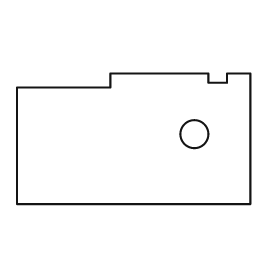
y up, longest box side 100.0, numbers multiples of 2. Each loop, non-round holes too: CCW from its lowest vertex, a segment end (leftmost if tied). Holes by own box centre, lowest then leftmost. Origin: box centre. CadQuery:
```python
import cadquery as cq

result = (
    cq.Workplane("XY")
    .moveTo(-50.0, -28.0)
    .lineTo(50.0, -28.0)
    .lineTo(50.0, 28.0)
    .lineTo(40.0, 28.0)
    .lineTo(40.0, 24.0)
    .lineTo(32.0, 24.0)
    .lineTo(32.0, 28.0)
    .lineTo(-10.0, 28.0)
    .lineTo(-10.0, 22.0)
    .lineTo(-50.0, 22.0)
    .close()
    .moveTo(26.0, 2.0)
    .circle(6.0)
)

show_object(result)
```